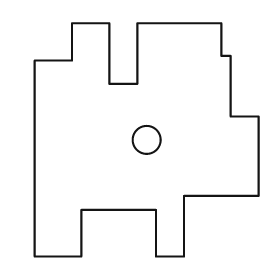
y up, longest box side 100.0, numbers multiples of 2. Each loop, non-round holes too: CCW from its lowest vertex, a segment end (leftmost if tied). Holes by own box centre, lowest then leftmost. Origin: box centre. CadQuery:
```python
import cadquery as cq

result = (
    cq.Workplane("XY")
    .moveTo(-48.0, -50.0)
    .lineTo(-28.0, -50.0)
    .lineTo(-28.0, -30.0)
    .lineTo(4.0, -30.0)
    .lineTo(4.0, -50.0)
    .lineTo(16.0, -50.0)
    .lineTo(16.0, -24.0)
    .lineTo(48.0, -24.0)
    .lineTo(48.0, 10.0)
    .lineTo(36.0, 10.0)
    .lineTo(36.0, 36.0)
    .lineTo(32.0, 36.0)
    .lineTo(32.0, 50.0)
    .lineTo(-4.0, 50.0)
    .lineTo(-4.0, 24.0)
    .lineTo(-16.0, 24.0)
    .lineTo(-16.0, 50.0)
    .lineTo(-32.0, 50.0)
    .lineTo(-32.0, 34.0)
    .lineTo(-48.0, 34.0)
    .close()
    .moveTo(0.0, 0.0)
    .circle(6.0)
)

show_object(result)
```